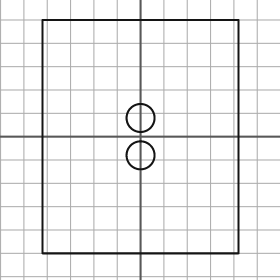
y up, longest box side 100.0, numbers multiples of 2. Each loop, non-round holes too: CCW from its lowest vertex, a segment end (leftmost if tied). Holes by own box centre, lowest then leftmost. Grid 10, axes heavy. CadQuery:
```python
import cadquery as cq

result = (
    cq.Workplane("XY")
    .moveTo(-42.0, -50.0)
    .lineTo(42.0, -50.0)
    .lineTo(42.0, 50.0)
    .lineTo(-42.0, 50.0)
    .close()
    .moveTo(0.0, -8.0)
    .circle(6.0)
    .moveTo(0.0, 8.0)
    .circle(6.0)
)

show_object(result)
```